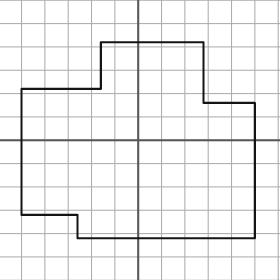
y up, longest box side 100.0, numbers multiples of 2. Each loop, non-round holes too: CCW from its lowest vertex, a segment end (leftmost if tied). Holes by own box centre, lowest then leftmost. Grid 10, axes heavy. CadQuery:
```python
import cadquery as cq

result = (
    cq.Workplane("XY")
    .moveTo(-26.0, -42.0)
    .lineTo(50.0, -42.0)
    .lineTo(50.0, 16.0)
    .lineTo(28.0, 16.0)
    .lineTo(28.0, 42.0)
    .lineTo(-16.0, 42.0)
    .lineTo(-16.0, 22.0)
    .lineTo(-50.0, 22.0)
    .lineTo(-50.0, -32.0)
    .lineTo(-26.0, -32.0)
    .close()
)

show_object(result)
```